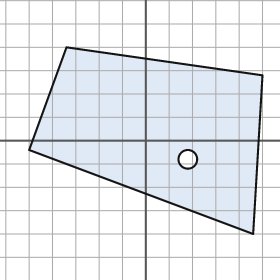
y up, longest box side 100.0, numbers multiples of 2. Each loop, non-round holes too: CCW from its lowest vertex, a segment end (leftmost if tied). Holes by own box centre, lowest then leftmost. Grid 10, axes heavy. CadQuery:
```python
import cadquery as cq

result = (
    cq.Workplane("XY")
    .moveTo(46.0, -40.0)
    .lineTo(50.0, 28.0)
    .lineTo(-34.0, 40.0)
    .lineTo(-50.0, -4.0)
    .close()
    .moveTo(18.0, -8.0)
    .circle(4.0)
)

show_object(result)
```